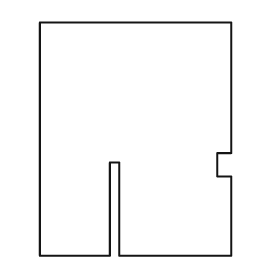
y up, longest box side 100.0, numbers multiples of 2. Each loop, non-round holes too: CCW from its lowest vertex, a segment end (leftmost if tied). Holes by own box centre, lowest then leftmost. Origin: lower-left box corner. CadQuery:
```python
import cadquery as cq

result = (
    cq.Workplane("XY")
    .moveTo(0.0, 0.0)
    .lineTo(30.0, 0.0)
    .lineTo(30.0, 40.0)
    .lineTo(34.0, 40.0)
    .lineTo(34.0, 0.0)
    .lineTo(82.0, 0.0)
    .lineTo(82.0, 34.0)
    .lineTo(76.0, 34.0)
    .lineTo(76.0, 44.0)
    .lineTo(82.0, 44.0)
    .lineTo(82.0, 100.0)
    .lineTo(0.0, 100.0)
    .close()
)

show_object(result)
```